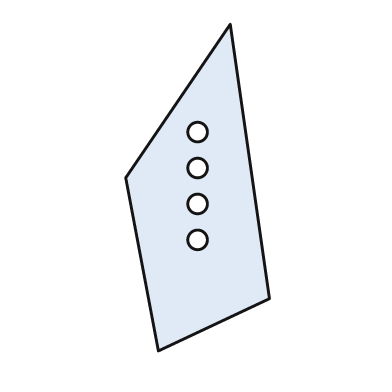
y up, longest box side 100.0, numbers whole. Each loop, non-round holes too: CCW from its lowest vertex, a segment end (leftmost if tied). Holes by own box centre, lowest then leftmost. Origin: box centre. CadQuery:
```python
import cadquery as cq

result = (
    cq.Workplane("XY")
    .moveTo(-12.0, -50.0)
    .lineTo(22.0, -34.0)
    .lineTo(10.0, 50.0)
    .lineTo(-22.0, 3.0)
    .close()
    .moveTo(0.0, -16.0)
    .circle(3.0)
    .moveTo(0.0, -5.0)
    .circle(3.0)
    .moveTo(0.0, 6.0)
    .circle(3.0)
    .moveTo(0.0, 17.0)
    .circle(3.0)
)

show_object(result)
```